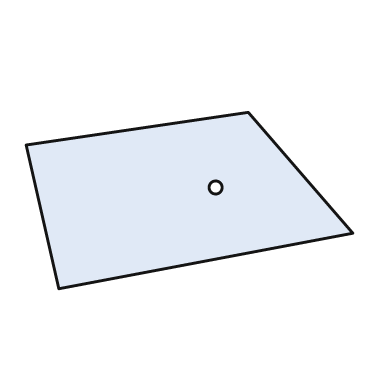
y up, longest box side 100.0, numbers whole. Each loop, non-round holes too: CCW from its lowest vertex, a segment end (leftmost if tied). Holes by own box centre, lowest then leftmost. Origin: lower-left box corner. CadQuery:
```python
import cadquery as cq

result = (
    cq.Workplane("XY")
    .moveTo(10.0, 0.0)
    .lineTo(100.0, 17.0)
    .lineTo(68.0, 54.0)
    .lineTo(0.0, 44.0)
    .close()
    .moveTo(58.0, 31.0)
    .circle(2.0)
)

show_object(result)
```